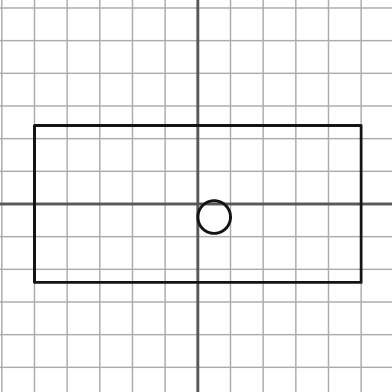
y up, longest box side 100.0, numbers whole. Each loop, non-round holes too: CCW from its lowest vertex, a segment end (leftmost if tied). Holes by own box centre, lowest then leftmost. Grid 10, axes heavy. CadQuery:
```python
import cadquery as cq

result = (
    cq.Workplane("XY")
    .moveTo(-50.0, -24.0)
    .lineTo(50.0, -24.0)
    .lineTo(50.0, 24.0)
    .lineTo(-50.0, 24.0)
    .close()
    .moveTo(5.0, -4.0)
    .circle(5.0)
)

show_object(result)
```